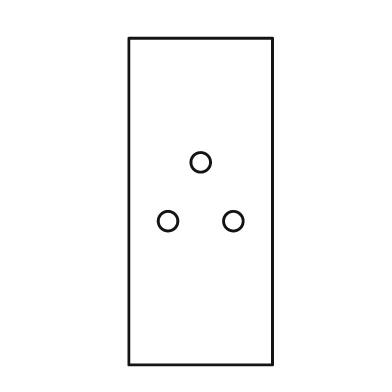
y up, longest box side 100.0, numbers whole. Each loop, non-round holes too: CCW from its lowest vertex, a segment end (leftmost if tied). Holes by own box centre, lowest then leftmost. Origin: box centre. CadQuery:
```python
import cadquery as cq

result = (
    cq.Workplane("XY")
    .moveTo(-22.0, -50.0)
    .lineTo(22.0, -50.0)
    .lineTo(22.0, 50.0)
    .lineTo(-22.0, 50.0)
    .close()
    .moveTo(-10.0, -6.0)
    .circle(3.0)
    .moveTo(10.0, -6.0)
    .circle(3.0)
    .moveTo(0.0, 12.0)
    .circle(3.0)
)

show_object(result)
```